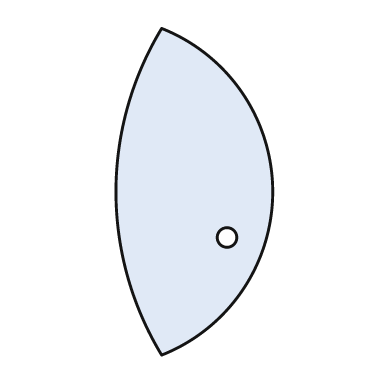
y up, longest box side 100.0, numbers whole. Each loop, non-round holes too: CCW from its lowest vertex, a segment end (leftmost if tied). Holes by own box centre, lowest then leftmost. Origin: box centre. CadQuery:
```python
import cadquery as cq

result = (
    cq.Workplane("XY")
    .moveTo(-10.0, -50.0)
    .threePointArc((24.0, 0.0), (-10.0, 50.0))
    .threePointArc((-24.0, 0.0), (-10.0, -50.0))
    .close()
    .moveTo(10.0, -14.0)
    .circle(3.0)
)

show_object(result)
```